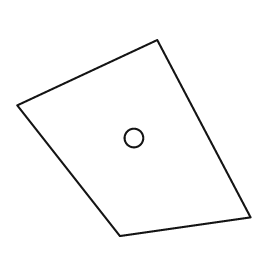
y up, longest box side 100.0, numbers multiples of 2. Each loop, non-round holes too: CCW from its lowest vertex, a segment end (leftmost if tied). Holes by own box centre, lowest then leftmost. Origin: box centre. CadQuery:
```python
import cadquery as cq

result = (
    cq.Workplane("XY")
    .moveTo(-6.0, -42.0)
    .lineTo(50.0, -34.0)
    .lineTo(10.0, 42.0)
    .lineTo(-50.0, 14.0)
    .close()
    .moveTo(0.0, 0.0)
    .circle(4.0)
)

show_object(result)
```